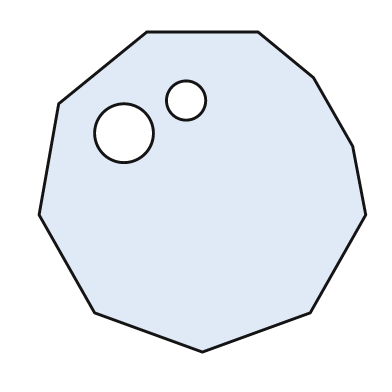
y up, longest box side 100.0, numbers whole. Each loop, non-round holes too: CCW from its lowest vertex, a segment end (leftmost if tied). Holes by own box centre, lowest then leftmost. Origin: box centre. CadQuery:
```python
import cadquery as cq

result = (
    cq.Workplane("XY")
    .moveTo(0.0, -49.0)
    .lineTo(33.0, -37.0)
    .lineTo(50.0, -7.0)
    .lineTo(46.0, 14.0)
    .lineTo(34.0, 35.0)
    .lineTo(17.0, 49.0)
    .lineTo(-17.0, 49.0)
    .lineTo(-44.0, 27.0)
    .lineTo(-50.0, -7.0)
    .lineTo(-33.0, -37.0)
    .close()
    .moveTo(-24.0, 18.0)
    .circle(9.0)
    .moveTo(-5.0, 28.0)
    .circle(6.0)
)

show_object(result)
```